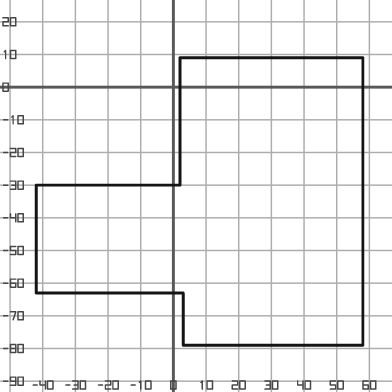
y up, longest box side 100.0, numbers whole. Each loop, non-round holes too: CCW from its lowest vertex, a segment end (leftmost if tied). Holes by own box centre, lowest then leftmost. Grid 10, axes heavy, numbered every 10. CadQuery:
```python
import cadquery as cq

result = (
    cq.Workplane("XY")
    .moveTo(3.0, -79.0)
    .lineTo(58.0, -79.0)
    .lineTo(58.0, 9.0)
    .lineTo(2.0, 9.0)
    .lineTo(2.0, -30.0)
    .lineTo(-42.0, -30.0)
    .lineTo(-42.0, -63.0)
    .lineTo(3.0, -63.0)
    .close()
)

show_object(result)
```